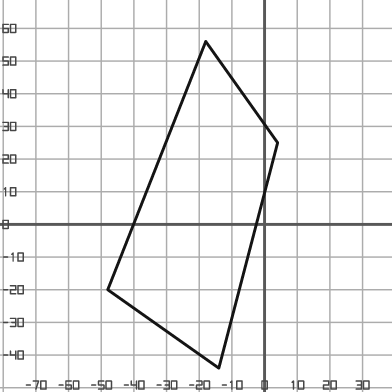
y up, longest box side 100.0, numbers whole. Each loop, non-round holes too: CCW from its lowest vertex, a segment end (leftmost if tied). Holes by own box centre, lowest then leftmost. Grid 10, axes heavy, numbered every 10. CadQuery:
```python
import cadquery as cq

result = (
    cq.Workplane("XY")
    .moveTo(-14.0, -44.0)
    .lineTo(4.0, 25.0)
    .lineTo(-18.0, 56.0)
    .lineTo(-48.0, -20.0)
    .close()
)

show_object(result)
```